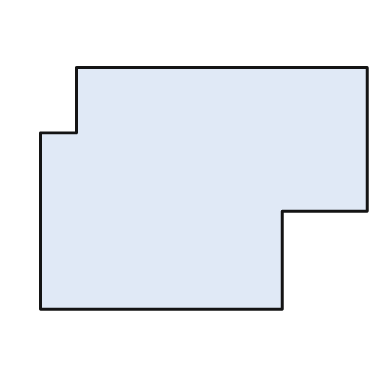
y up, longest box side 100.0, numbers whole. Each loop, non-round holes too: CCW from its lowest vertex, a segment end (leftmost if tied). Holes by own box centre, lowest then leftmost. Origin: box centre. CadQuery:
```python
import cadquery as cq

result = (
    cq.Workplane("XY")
    .moveTo(-50.0, -37.0)
    .lineTo(24.0, -37.0)
    .lineTo(24.0, -7.0)
    .lineTo(50.0, -7.0)
    .lineTo(50.0, 37.0)
    .lineTo(-39.0, 37.0)
    .lineTo(-39.0, 17.0)
    .lineTo(-50.0, 17.0)
    .close()
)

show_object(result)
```